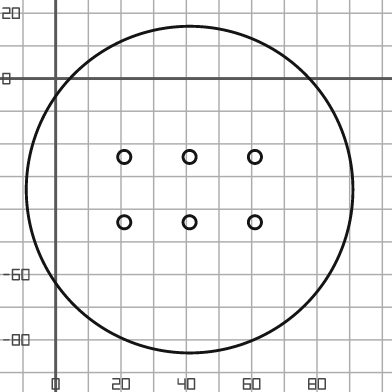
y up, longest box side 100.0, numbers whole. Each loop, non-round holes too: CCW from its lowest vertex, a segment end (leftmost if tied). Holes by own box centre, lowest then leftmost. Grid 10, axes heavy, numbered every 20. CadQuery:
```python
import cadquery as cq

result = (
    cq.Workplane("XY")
    .moveTo(41.0, -34.0)
    .circle(50.0)
    .moveTo(21.0, -44.0)
    .circle(2.0)
    .moveTo(41.0, -44.0)
    .circle(2.0)
    .moveTo(61.0, -44.0)
    .circle(2.0)
    .moveTo(21.0, -24.0)
    .circle(2.0)
    .moveTo(41.0, -24.0)
    .circle(2.0)
    .moveTo(61.0, -24.0)
    .circle(2.0)
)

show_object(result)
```